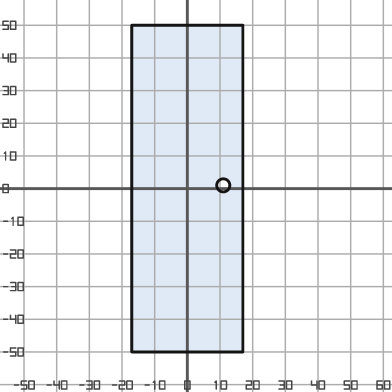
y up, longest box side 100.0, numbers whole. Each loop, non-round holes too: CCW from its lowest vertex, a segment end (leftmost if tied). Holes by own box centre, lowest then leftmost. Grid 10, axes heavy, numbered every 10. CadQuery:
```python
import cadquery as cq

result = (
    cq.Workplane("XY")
    .moveTo(-17.0, -50.0)
    .lineTo(17.0, -50.0)
    .lineTo(17.0, 50.0)
    .lineTo(-17.0, 50.0)
    .close()
    .moveTo(11.0, 1.0)
    .circle(2.0)
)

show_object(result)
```